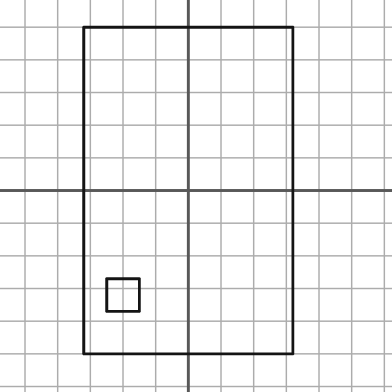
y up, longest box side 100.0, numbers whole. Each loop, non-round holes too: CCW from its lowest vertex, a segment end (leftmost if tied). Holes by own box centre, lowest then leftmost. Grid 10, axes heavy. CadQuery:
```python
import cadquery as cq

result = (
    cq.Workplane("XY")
    .moveTo(-32.0, -50.0)
    .lineTo(32.0, -50.0)
    .lineTo(32.0, 50.0)
    .lineTo(-32.0, 50.0)
    .close()
    .moveTo(-25.0, -37.0)
    .lineTo(-15.0, -37.0)
    .lineTo(-15.0, -27.0)
    .lineTo(-25.0, -27.0)
    .close()
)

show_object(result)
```